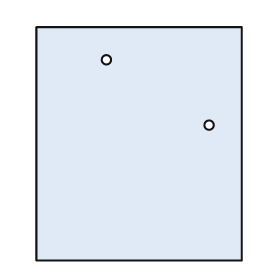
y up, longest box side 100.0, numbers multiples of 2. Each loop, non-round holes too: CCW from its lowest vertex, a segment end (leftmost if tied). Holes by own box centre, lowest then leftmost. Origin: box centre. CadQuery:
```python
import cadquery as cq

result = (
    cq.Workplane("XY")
    .moveTo(-44.0, -50.0)
    .lineTo(44.0, -50.0)
    .lineTo(44.0, 50.0)
    .lineTo(-44.0, 50.0)
    .close()
    .moveTo(30.0, 8.0)
    .circle(2.0)
    .moveTo(-14.0, 36.0)
    .circle(2.0)
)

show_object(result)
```